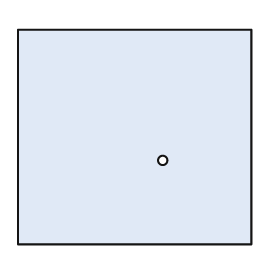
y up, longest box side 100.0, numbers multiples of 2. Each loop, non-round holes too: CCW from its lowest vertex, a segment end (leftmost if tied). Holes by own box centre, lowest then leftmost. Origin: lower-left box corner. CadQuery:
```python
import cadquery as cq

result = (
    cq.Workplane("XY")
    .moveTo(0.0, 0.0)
    .lineTo(100.0, 0.0)
    .lineTo(100.0, 92.0)
    .lineTo(0.0, 92.0)
    .close()
    .moveTo(62.0, 36.0)
    .circle(2.0)
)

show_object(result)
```